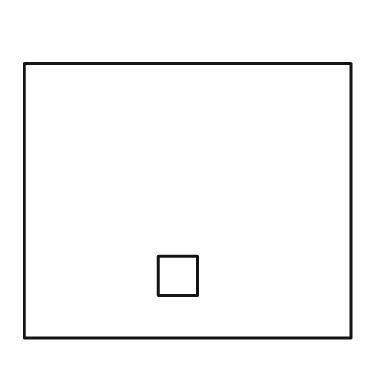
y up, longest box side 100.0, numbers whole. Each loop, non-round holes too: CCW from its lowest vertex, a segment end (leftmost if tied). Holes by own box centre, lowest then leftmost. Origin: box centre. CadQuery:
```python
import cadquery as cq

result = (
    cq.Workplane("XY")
    .moveTo(-50.0, -42.0)
    .lineTo(50.0, -42.0)
    .lineTo(50.0, 42.0)
    .lineTo(-50.0, 42.0)
    .close()
    .moveTo(-9.0, -29.0)
    .lineTo(3.0, -29.0)
    .lineTo(3.0, -17.0)
    .lineTo(-9.0, -17.0)
    .close()
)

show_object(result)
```